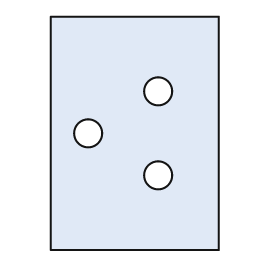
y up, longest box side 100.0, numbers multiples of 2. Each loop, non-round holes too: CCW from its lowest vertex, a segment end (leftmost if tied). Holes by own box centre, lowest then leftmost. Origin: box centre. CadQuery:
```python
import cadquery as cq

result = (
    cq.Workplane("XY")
    .moveTo(-36.0, -50.0)
    .lineTo(36.0, -50.0)
    .lineTo(36.0, 50.0)
    .lineTo(-36.0, 50.0)
    .close()
    .moveTo(10.0, -18.0)
    .circle(6.0)
    .moveTo(-20.0, 0.0)
    .circle(6.0)
    .moveTo(10.0, 18.0)
    .circle(6.0)
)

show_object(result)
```